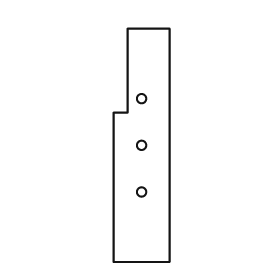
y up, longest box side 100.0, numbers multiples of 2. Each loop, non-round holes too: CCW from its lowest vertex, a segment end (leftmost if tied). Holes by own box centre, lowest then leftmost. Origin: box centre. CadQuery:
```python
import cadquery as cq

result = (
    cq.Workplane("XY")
    .moveTo(-12.0, -50.0)
    .lineTo(12.0, -50.0)
    .lineTo(12.0, 50.0)
    .lineTo(-6.0, 50.0)
    .lineTo(-6.0, 14.0)
    .lineTo(-12.0, 14.0)
    .close()
    .moveTo(0.0, -20.0)
    .circle(2.0)
    .moveTo(0.0, 0.0)
    .circle(2.0)
    .moveTo(0.0, 20.0)
    .circle(2.0)
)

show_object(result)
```